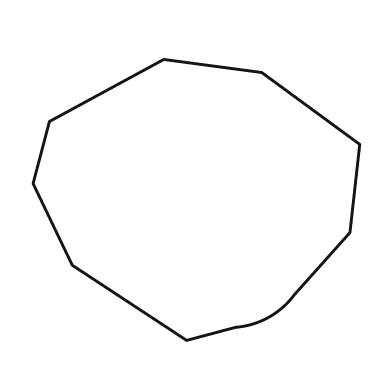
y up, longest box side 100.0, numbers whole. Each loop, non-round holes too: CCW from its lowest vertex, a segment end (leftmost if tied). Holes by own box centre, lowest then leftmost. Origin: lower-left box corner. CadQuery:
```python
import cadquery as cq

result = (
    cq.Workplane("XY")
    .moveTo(47.0, 0.0)
    .lineTo(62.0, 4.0)
    .threePointArc((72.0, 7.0), (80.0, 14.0))
    .lineTo(97.0, 33.0)
    .lineTo(100.0, 60.0)
    .lineTo(70.0, 82.0)
    .lineTo(40.0, 86.0)
    .lineTo(5.0, 67.0)
    .lineTo(0.0, 48.0)
    .lineTo(12.0, 23.0)
    .close()
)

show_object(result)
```